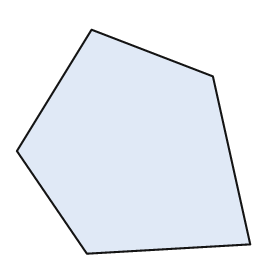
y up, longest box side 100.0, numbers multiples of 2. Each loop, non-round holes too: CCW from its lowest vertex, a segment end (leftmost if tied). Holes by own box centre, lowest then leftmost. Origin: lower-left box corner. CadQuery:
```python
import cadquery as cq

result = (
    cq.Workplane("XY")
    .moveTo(30.0, 0.0)
    .lineTo(100.0, 4.0)
    .lineTo(84.0, 76.0)
    .lineTo(32.0, 96.0)
    .lineTo(0.0, 44.0)
    .close()
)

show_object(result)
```